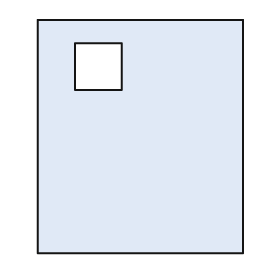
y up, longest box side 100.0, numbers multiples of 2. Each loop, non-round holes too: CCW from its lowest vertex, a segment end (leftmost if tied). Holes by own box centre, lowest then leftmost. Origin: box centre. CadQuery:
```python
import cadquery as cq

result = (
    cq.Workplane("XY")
    .moveTo(-44.0, -50.0)
    .lineTo(44.0, -50.0)
    .lineTo(44.0, 50.0)
    .lineTo(-44.0, 50.0)
    .close()
    .moveTo(-28.0, 20.0)
    .lineTo(-8.0, 20.0)
    .lineTo(-8.0, 40.0)
    .lineTo(-28.0, 40.0)
    .close()
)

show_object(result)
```